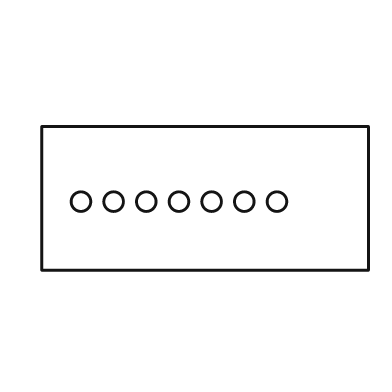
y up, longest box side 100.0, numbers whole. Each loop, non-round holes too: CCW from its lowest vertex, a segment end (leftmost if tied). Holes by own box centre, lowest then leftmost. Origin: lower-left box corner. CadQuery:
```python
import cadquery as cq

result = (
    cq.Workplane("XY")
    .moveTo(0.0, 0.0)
    .lineTo(100.0, 0.0)
    .lineTo(100.0, 44.0)
    .lineTo(0.0, 44.0)
    .close()
    .moveTo(12.0, 21.0)
    .circle(3.0)
    .moveTo(22.0, 21.0)
    .circle(3.0)
    .moveTo(32.0, 21.0)
    .circle(3.0)
    .moveTo(42.0, 21.0)
    .circle(3.0)
    .moveTo(52.0, 21.0)
    .circle(3.0)
    .moveTo(62.0, 21.0)
    .circle(3.0)
    .moveTo(72.0, 21.0)
    .circle(3.0)
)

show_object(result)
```